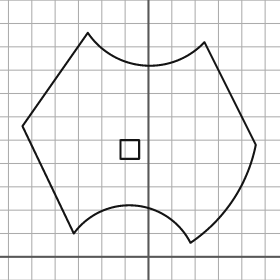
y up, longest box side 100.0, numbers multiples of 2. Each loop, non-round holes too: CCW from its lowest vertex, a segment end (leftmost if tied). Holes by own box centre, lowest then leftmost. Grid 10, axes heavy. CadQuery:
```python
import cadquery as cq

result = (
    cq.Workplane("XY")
    .moveTo(18.0, 6.0)
    .threePointArc((36.0, 24.0), (46.0, 48.0))
    .lineTo(24.0, 92.0)
    .threePointArc((-2.0, 82.0), (-26.0, 96.0))
    .lineTo(-54.0, 56.0)
    .lineTo(-32.0, 10.0)
    .threePointArc((-6.0, 22.0), (18.0, 6.0))
    .close()
    .moveTo(-12.0, 42.0)
    .lineTo(-4.0, 42.0)
    .lineTo(-4.0, 50.0)
    .lineTo(-12.0, 50.0)
    .close()
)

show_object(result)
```